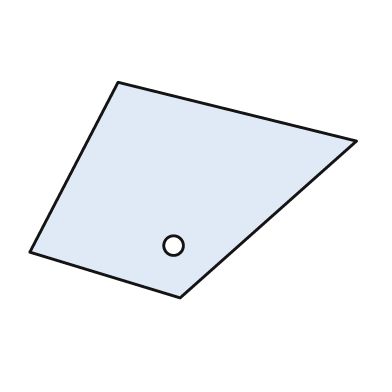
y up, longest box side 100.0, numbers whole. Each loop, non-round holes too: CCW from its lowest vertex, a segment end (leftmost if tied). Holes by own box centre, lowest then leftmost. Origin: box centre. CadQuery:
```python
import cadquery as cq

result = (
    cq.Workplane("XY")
    .moveTo(-4.0, -33.0)
    .lineTo(50.0, 15.0)
    .lineTo(-23.0, 33.0)
    .lineTo(-50.0, -19.0)
    .close()
    .moveTo(-6.0, -17.0)
    .circle(3.0)
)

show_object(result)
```